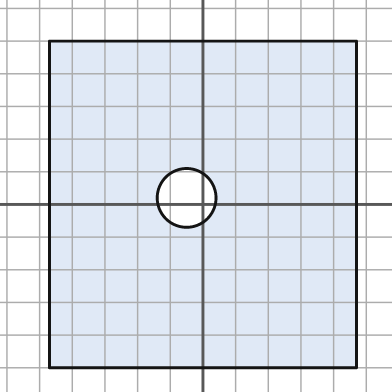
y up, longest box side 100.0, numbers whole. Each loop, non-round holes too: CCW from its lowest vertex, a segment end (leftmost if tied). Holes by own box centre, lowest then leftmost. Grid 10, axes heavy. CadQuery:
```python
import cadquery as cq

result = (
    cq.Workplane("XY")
    .moveTo(-47.0, -50.0)
    .lineTo(47.0, -50.0)
    .lineTo(47.0, 50.0)
    .lineTo(-47.0, 50.0)
    .close()
    .moveTo(-5.0, 2.0)
    .circle(9.0)
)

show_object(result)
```